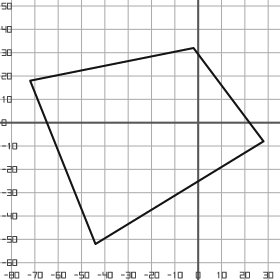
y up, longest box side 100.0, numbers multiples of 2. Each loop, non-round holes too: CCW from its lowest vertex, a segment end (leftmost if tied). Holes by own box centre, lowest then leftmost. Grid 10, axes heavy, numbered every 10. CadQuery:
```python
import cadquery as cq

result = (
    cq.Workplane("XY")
    .moveTo(-44.0, -52.0)
    .lineTo(28.0, -8.0)
    .lineTo(-2.0, 32.0)
    .lineTo(-72.0, 18.0)
    .close()
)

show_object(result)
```